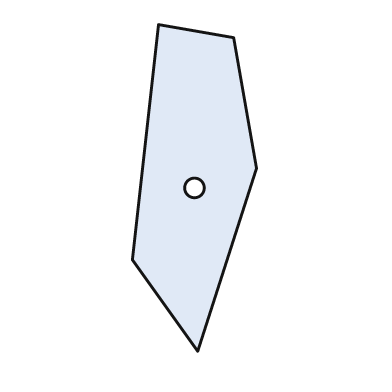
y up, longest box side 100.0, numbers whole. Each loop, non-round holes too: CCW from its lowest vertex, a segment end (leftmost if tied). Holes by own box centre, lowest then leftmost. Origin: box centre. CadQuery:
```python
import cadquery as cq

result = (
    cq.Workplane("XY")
    .moveTo(1.0, -50.0)
    .lineTo(19.0, 6.0)
    .lineTo(12.0, 46.0)
    .lineTo(-11.0, 50.0)
    .lineTo(-19.0, -22.0)
    .close()
    .moveTo(0.0, 0.0)
    .circle(3.0)
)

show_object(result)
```